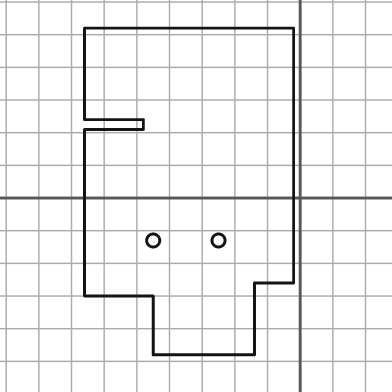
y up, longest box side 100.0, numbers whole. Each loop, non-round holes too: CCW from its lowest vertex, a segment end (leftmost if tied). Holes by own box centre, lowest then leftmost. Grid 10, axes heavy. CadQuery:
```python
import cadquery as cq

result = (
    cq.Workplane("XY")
    .moveTo(-45.0, -48.0)
    .lineTo(-14.0, -48.0)
    .lineTo(-14.0, -26.0)
    .lineTo(-2.0, -26.0)
    .lineTo(-2.0, 52.0)
    .lineTo(-66.0, 52.0)
    .lineTo(-66.0, 24.0)
    .lineTo(-48.0, 24.0)
    .lineTo(-48.0, 21.0)
    .lineTo(-66.0, 21.0)
    .lineTo(-66.0, -30.0)
    .lineTo(-45.0, -30.0)
    .close()
    .moveTo(-45.0, -13.0)
    .circle(2.0)
    .moveTo(-25.0, -13.0)
    .circle(2.0)
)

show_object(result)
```